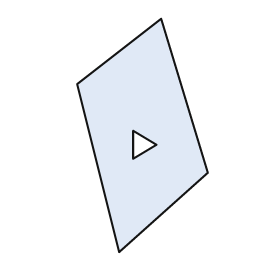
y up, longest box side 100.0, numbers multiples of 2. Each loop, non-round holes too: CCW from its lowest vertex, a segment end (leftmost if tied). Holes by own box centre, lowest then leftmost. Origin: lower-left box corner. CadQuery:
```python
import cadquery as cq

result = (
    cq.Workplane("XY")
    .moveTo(18.0, 0.0)
    .lineTo(56.0, 34.0)
    .lineTo(36.0, 100.0)
    .lineTo(0.0, 72.0)
    .close()
    .moveTo(24.0, 40.0)
    .lineTo(34.0, 46.0)
    .lineTo(24.0, 52.0)
    .close()
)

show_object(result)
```